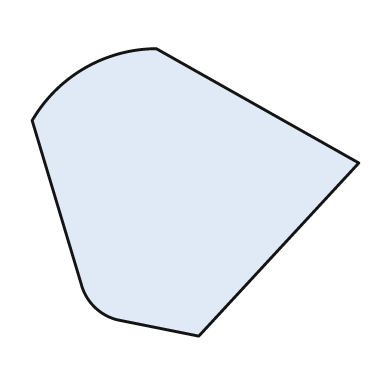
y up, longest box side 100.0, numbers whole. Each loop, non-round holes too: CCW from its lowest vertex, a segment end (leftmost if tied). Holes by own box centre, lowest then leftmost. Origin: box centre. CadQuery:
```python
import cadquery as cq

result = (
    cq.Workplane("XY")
    .moveTo(1.0, -44.0)
    .lineTo(50.0, 9.0)
    .lineTo(-12.0, 44.0)
    .threePointArc((-34.0, 38.0), (-50.0, 22.0))
    .lineTo(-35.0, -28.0)
    .threePointArc((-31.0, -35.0), (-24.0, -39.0))
    .close()
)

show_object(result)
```